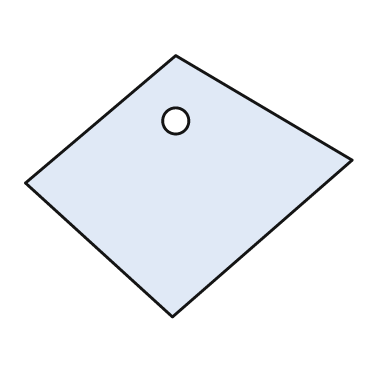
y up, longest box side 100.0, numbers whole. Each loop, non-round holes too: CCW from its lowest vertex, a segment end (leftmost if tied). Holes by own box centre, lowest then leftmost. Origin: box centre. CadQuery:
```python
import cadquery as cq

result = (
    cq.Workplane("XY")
    .moveTo(-5.0, -40.0)
    .lineTo(50.0, 8.0)
    .lineTo(-4.0, 40.0)
    .lineTo(-50.0, 1.0)
    .close()
    .moveTo(-4.0, 20.0)
    .circle(4.0)
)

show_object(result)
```